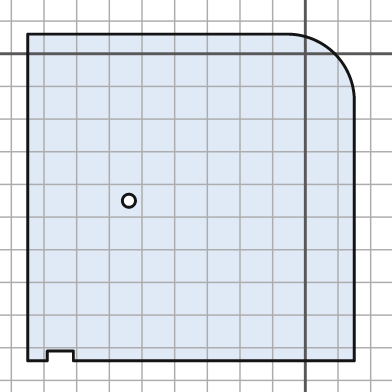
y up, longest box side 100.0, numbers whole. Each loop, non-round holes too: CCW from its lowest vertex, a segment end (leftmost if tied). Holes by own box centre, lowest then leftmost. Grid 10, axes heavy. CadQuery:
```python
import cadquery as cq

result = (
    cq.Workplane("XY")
    .moveTo(-85.0, -94.0)
    .lineTo(-79.0, -94.0)
    .lineTo(-79.0, -91.0)
    .lineTo(-71.0, -91.0)
    .lineTo(-71.0, -94.0)
    .lineTo(15.0, -94.0)
    .lineTo(15.0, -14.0)
    .threePointArc((9.0, 0.0), (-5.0, 6.0))
    .lineTo(-85.0, 6.0)
    .close()
    .moveTo(-54.0, -45.0)
    .circle(2.0)
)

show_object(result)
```